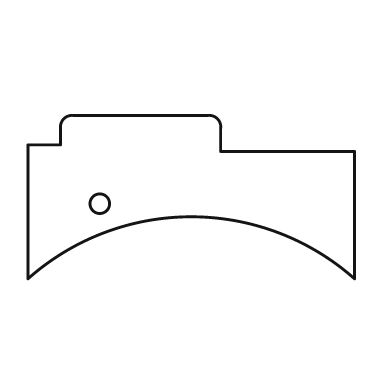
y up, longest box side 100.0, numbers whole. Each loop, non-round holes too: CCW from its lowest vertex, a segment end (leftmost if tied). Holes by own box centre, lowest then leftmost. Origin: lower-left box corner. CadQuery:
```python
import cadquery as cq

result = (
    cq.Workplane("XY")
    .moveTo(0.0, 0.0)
    .threePointArc((50.0, 19.0), (100.0, 0.0))
    .lineTo(100.0, 39.0)
    .lineTo(59.0, 39.0)
    .lineTo(59.0, 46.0)
    .threePointArc((58.0, 49.0), (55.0, 50.0))
    .lineTo(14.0, 50.0)
    .threePointArc((11.0, 49.0), (10.0, 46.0))
    .lineTo(10.0, 41.0)
    .lineTo(0.0, 41.0)
    .close()
    .moveTo(22.0, 23.0)
    .circle(3.0)
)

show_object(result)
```